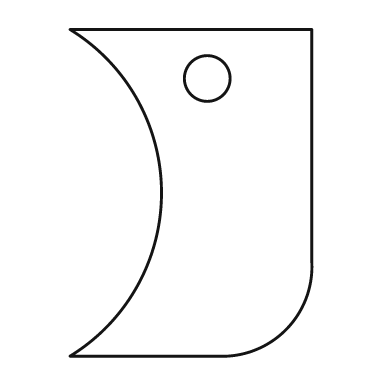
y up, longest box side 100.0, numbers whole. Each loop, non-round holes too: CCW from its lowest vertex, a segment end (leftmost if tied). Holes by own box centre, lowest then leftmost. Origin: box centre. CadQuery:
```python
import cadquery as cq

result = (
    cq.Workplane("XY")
    .moveTo(-37.0, -50.0)
    .lineTo(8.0, -50.0)
    .threePointArc((29.0, -42.0), (37.0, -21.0))
    .lineTo(37.0, 50.0)
    .lineTo(-37.0, 50.0)
    .threePointArc((-9.0, 0.0), (-37.0, -50.0))
    .close()
    .moveTo(5.0, 35.0)
    .circle(7.0)
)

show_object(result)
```